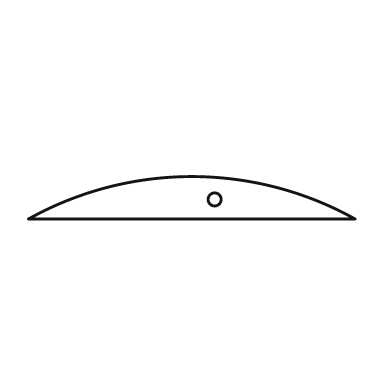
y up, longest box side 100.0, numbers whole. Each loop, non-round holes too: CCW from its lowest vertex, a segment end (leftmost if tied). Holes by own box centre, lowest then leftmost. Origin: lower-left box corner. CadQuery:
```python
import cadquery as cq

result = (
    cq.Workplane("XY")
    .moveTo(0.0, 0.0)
    .lineTo(100.0, 0.0)
    .threePointArc((50.0, 13.0), (0.0, 0.0))
    .close()
    .moveTo(57.0, 6.0)
    .circle(2.0)
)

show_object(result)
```